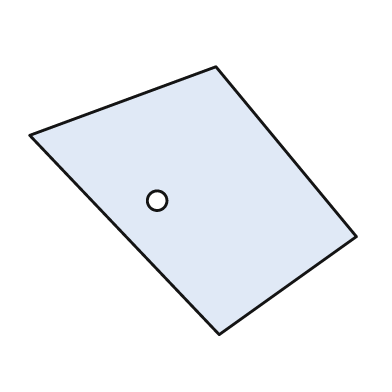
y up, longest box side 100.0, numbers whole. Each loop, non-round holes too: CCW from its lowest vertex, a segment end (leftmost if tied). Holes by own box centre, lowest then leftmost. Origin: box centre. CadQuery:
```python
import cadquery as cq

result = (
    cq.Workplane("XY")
    .moveTo(8.0, -41.0)
    .lineTo(50.0, -11.0)
    .lineTo(7.0, 41.0)
    .lineTo(-50.0, 20.0)
    .close()
    .moveTo(-11.0, 0.0)
    .circle(3.0)
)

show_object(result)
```